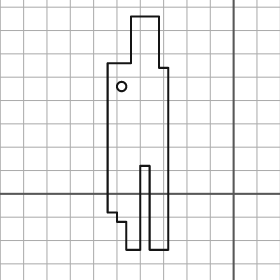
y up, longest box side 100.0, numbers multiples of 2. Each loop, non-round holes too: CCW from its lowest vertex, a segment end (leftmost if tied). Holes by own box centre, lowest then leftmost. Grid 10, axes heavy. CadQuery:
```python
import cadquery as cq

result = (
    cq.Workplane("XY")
    .moveTo(-46.0, -24.0)
    .lineTo(-40.0, -24.0)
    .lineTo(-40.0, 12.0)
    .lineTo(-36.0, 12.0)
    .lineTo(-36.0, -24.0)
    .lineTo(-28.0, -24.0)
    .lineTo(-28.0, 54.0)
    .lineTo(-32.0, 54.0)
    .lineTo(-32.0, 76.0)
    .lineTo(-44.0, 76.0)
    .lineTo(-44.0, 56.0)
    .lineTo(-54.0, 56.0)
    .lineTo(-54.0, -8.0)
    .lineTo(-50.0, -8.0)
    .lineTo(-50.0, -12.0)
    .lineTo(-46.0, -12.0)
    .close()
    .moveTo(-48.0, 46.0)
    .circle(2.0)
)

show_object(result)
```